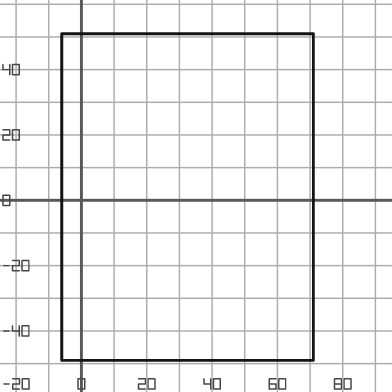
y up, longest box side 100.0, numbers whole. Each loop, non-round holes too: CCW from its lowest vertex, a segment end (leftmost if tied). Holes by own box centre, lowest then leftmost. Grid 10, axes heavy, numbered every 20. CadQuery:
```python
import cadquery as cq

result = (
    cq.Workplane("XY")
    .moveTo(-6.0, -49.0)
    .lineTo(71.0, -49.0)
    .lineTo(71.0, 51.0)
    .lineTo(-6.0, 51.0)
    .close()
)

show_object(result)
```